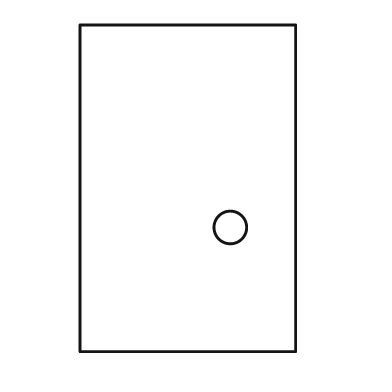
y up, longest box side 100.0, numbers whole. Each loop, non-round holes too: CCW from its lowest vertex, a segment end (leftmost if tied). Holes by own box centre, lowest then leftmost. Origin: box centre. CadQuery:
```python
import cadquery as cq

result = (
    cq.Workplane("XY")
    .moveTo(-33.0, -50.0)
    .lineTo(33.0, -50.0)
    .lineTo(33.0, 50.0)
    .lineTo(-33.0, 50.0)
    .close()
    .moveTo(13.0, -12.0)
    .circle(5.0)
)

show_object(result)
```